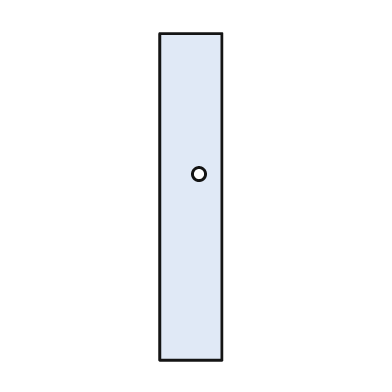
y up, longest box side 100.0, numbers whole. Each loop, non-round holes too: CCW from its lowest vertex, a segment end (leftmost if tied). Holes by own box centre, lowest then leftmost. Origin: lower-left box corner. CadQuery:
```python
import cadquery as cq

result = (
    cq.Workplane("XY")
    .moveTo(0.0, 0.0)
    .lineTo(19.0, 0.0)
    .lineTo(19.0, 100.0)
    .lineTo(0.0, 100.0)
    .close()
    .moveTo(12.0, 57.0)
    .circle(2.0)
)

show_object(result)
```